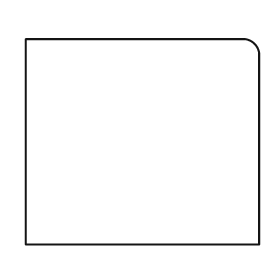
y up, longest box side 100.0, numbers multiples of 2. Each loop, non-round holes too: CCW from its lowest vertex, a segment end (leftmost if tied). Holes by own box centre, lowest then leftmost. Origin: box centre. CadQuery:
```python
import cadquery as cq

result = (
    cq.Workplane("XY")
    .moveTo(-50.0, -44.0)
    .lineTo(50.0, -44.0)
    .lineTo(50.0, 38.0)
    .threePointArc((48.0, 42.0), (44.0, 44.0))
    .lineTo(-50.0, 44.0)
    .close()
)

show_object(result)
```